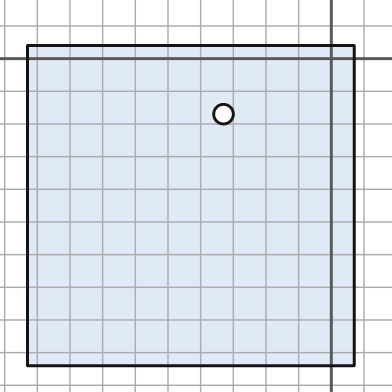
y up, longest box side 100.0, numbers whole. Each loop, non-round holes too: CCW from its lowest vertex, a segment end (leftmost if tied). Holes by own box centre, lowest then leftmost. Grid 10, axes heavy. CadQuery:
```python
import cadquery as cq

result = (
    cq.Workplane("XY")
    .moveTo(-93.0, -94.0)
    .lineTo(7.0, -94.0)
    .lineTo(7.0, 4.0)
    .lineTo(-93.0, 4.0)
    .close()
    .moveTo(-33.0, -17.0)
    .circle(3.0)
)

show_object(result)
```